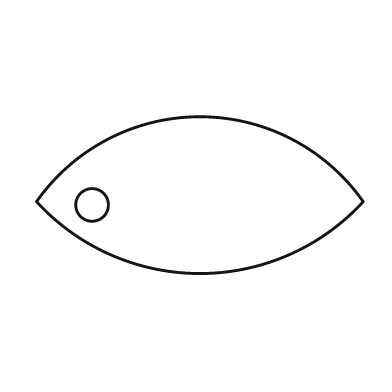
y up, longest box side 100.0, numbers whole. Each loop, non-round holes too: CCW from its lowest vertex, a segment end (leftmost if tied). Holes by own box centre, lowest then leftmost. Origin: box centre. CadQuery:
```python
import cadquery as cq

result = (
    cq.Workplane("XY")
    .moveTo(-50.0, -2.0)
    .threePointArc((0.0, -24.0), (50.0, -2.0))
    .threePointArc((0.0, 24.0), (-50.0, -2.0))
    .close()
    .moveTo(-33.0, -3.0)
    .circle(5.0)
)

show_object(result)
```